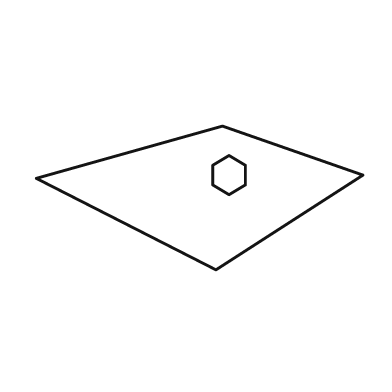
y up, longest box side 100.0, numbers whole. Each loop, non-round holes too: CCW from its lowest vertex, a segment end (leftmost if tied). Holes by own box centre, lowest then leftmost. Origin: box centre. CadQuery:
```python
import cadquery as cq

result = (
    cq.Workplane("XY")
    .moveTo(5.0, -22.0)
    .lineTo(50.0, 7.0)
    .lineTo(7.0, 22.0)
    .lineTo(-50.0, 6.0)
    .close()
    .moveTo(9.0, 1.0)
    .lineTo(14.0, 4.0)
    .lineTo(14.0, 10.0)
    .lineTo(9.0, 13.0)
    .lineTo(4.0, 10.0)
    .lineTo(4.0, 4.0)
    .close()
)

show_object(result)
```